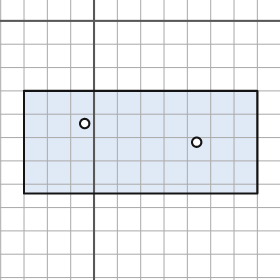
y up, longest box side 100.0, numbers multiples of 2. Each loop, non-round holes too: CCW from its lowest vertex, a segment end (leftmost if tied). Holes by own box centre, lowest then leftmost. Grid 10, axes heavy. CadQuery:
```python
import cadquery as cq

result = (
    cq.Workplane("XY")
    .moveTo(-30.0, -74.0)
    .lineTo(70.0, -74.0)
    .lineTo(70.0, -30.0)
    .lineTo(-30.0, -30.0)
    .close()
    .moveTo(44.0, -52.0)
    .circle(2.0)
    .moveTo(-4.0, -44.0)
    .circle(2.0)
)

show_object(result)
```